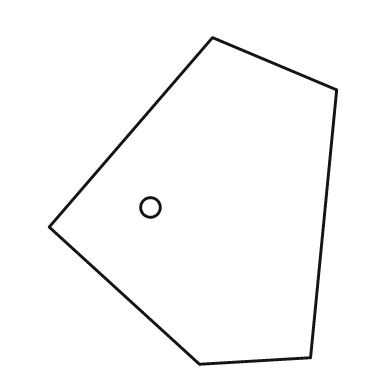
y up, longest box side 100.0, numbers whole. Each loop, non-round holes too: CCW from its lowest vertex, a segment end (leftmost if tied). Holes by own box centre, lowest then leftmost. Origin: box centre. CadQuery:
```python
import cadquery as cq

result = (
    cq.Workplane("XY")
    .moveTo(2.0, -50.0)
    .lineTo(36.0, -48.0)
    .lineTo(44.0, 34.0)
    .lineTo(6.0, 50.0)
    .lineTo(-44.0, -8.0)
    .close()
    .moveTo(-13.0, -2.0)
    .circle(3.0)
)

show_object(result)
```